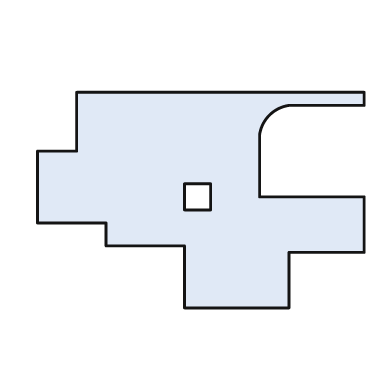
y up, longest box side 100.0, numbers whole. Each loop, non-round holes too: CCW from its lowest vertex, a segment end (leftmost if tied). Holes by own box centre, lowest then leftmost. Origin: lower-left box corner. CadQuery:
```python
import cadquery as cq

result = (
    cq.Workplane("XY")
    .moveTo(45.0, 0.0)
    .lineTo(77.0, 0.0)
    .lineTo(77.0, 17.0)
    .lineTo(100.0, 17.0)
    .lineTo(100.0, 34.0)
    .lineTo(68.0, 34.0)
    .lineTo(68.0, 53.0)
    .threePointArc((71.0, 59.0), (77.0, 62.0))
    .lineTo(100.0, 62.0)
    .lineTo(100.0, 66.0)
    .lineTo(12.0, 66.0)
    .lineTo(12.0, 48.0)
    .lineTo(0.0, 48.0)
    .lineTo(0.0, 26.0)
    .lineTo(21.0, 26.0)
    .lineTo(21.0, 19.0)
    .lineTo(45.0, 19.0)
    .close()
    .moveTo(45.0, 30.0)
    .lineTo(53.0, 30.0)
    .lineTo(53.0, 38.0)
    .lineTo(45.0, 38.0)
    .close()
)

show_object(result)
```